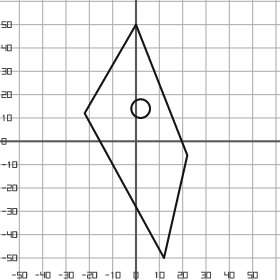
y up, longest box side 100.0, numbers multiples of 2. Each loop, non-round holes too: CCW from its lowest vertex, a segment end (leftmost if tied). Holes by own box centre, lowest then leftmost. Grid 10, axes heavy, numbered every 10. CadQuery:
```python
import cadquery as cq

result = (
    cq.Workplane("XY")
    .moveTo(12.0, -50.0)
    .lineTo(22.0, -6.0)
    .lineTo(0.0, 50.0)
    .lineTo(-22.0, 12.0)
    .close()
    .moveTo(2.0, 14.0)
    .circle(4.0)
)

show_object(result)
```